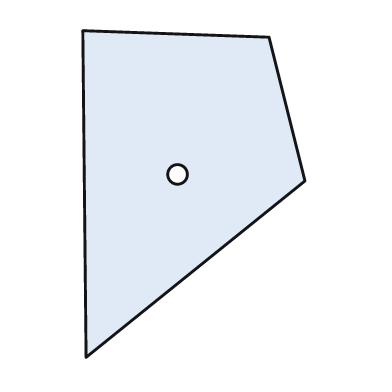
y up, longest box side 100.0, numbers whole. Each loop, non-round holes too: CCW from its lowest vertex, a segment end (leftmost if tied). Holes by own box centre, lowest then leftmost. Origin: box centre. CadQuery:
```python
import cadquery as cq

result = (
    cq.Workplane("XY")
    .moveTo(-33.0, -50.0)
    .lineTo(34.0, 4.0)
    .lineTo(23.0, 48.0)
    .lineTo(-34.0, 50.0)
    .close()
    .moveTo(-5.0, 6.0)
    .circle(3.0)
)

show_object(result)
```